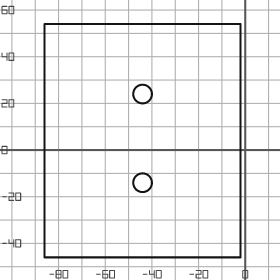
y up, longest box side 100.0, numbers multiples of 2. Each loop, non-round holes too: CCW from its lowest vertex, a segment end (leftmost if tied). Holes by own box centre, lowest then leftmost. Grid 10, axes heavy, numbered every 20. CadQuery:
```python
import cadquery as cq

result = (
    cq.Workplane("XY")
    .moveTo(-86.0, -46.0)
    .lineTo(-2.0, -46.0)
    .lineTo(-2.0, 54.0)
    .lineTo(-86.0, 54.0)
    .close()
    .moveTo(-44.0, -14.0)
    .circle(4.0)
    .moveTo(-44.0, 24.0)
    .circle(4.0)
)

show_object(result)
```